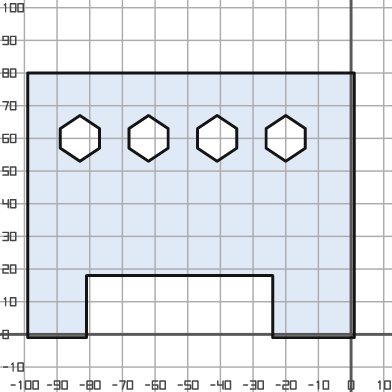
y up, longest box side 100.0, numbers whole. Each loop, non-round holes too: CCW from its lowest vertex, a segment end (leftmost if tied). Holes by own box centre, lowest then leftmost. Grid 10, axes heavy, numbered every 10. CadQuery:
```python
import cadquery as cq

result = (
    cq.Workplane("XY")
    .moveTo(-99.0, -1.0)
    .lineTo(-81.0, -1.0)
    .lineTo(-81.0, 18.0)
    .lineTo(-24.0, 18.0)
    .lineTo(-24.0, -1.0)
    .lineTo(1.0, -1.0)
    .lineTo(1.0, 80.0)
    .lineTo(-99.0, 80.0)
    .close()
    .moveTo(-83.0, 53.0)
    .lineTo(-77.0, 57.0)
    .lineTo(-77.0, 63.0)
    .lineTo(-83.0, 67.0)
    .lineTo(-89.0, 63.0)
    .lineTo(-89.0, 57.0)
    .close()
    .moveTo(-62.0, 53.0)
    .lineTo(-56.0, 57.0)
    .lineTo(-56.0, 63.0)
    .lineTo(-62.0, 67.0)
    .lineTo(-68.0, 63.0)
    .lineTo(-68.0, 57.0)
    .close()
    .moveTo(-41.0, 53.0)
    .lineTo(-35.0, 57.0)
    .lineTo(-35.0, 63.0)
    .lineTo(-41.0, 67.0)
    .lineTo(-47.0, 63.0)
    .lineTo(-47.0, 57.0)
    .close()
    .moveTo(-20.0, 53.0)
    .lineTo(-14.0, 57.0)
    .lineTo(-14.0, 63.0)
    .lineTo(-20.0, 67.0)
    .lineTo(-26.0, 63.0)
    .lineTo(-26.0, 57.0)
    .close()
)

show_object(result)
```